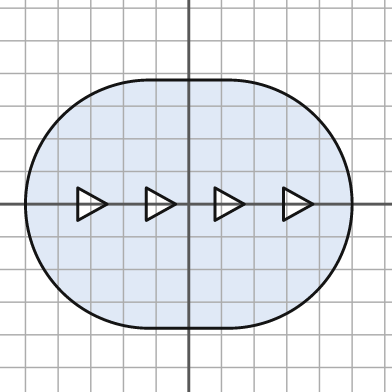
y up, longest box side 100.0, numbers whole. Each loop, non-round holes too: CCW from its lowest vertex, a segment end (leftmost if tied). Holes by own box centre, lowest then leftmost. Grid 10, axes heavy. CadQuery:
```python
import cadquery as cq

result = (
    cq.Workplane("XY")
    .moveTo(-12.0, -38.0)
    .lineTo(12.0, -38.0)
    .threePointArc((50.0, 0.0), (12.0, 38.0))
    .lineTo(-12.0, 38.0)
    .threePointArc((-50.0, 0.0), (-12.0, -38.0))
    .close()
    .moveTo(-34.0, -5.0)
    .lineTo(-25.0, 0.0)
    .lineTo(-34.0, 5.0)
    .close()
    .moveTo(-13.0, -5.0)
    .lineTo(-4.0, 0.0)
    .lineTo(-13.0, 5.0)
    .close()
    .moveTo(8.0, -5.0)
    .lineTo(17.0, 0.0)
    .lineTo(8.0, 5.0)
    .close()
    .moveTo(29.0, -5.0)
    .lineTo(38.0, 0.0)
    .lineTo(29.0, 5.0)
    .close()
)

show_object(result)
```